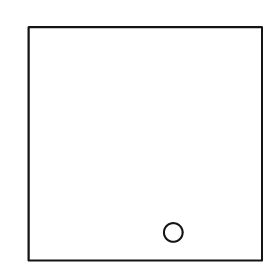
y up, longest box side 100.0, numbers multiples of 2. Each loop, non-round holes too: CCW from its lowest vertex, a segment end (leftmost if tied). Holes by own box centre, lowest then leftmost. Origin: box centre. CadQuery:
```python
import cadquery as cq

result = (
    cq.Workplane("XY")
    .moveTo(-50.0, -50.0)
    .lineTo(50.0, -50.0)
    .lineTo(50.0, 50.0)
    .lineTo(-50.0, 50.0)
    .close()
    .moveTo(12.0, -38.0)
    .circle(4.0)
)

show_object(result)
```